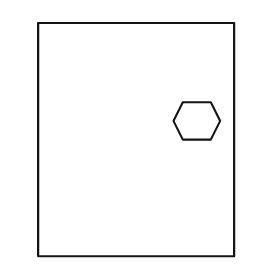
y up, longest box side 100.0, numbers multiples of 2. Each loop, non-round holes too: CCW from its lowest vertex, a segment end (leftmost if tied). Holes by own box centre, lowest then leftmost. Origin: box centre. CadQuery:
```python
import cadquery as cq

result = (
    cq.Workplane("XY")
    .moveTo(-42.0, -50.0)
    .lineTo(42.0, -50.0)
    .lineTo(42.0, 50.0)
    .lineTo(-42.0, 50.0)
    .close()
    .moveTo(20.0, 0.0)
    .lineTo(32.0, 0.0)
    .lineTo(36.0, 8.0)
    .lineTo(32.0, 16.0)
    .lineTo(20.0, 16.0)
    .lineTo(16.0, 8.0)
    .close()
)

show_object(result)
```